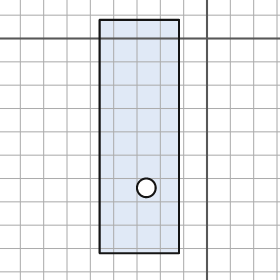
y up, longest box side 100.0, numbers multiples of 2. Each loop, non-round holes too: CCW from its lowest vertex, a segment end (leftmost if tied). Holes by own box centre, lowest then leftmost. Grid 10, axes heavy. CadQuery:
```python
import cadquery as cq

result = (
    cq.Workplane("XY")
    .moveTo(-46.0, -92.0)
    .lineTo(-12.0, -92.0)
    .lineTo(-12.0, 8.0)
    .lineTo(-46.0, 8.0)
    .close()
    .moveTo(-26.0, -64.0)
    .circle(4.0)
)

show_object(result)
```